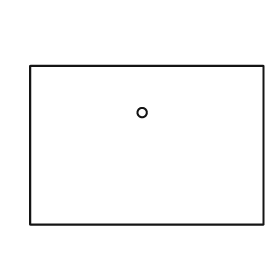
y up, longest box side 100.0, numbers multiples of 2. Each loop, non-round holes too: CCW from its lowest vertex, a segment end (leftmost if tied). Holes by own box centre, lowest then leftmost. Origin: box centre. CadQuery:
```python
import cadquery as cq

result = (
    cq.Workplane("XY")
    .moveTo(-50.0, -34.0)
    .lineTo(50.0, -34.0)
    .lineTo(50.0, 34.0)
    .lineTo(-50.0, 34.0)
    .close()
    .moveTo(-2.0, 14.0)
    .circle(2.0)
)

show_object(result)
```